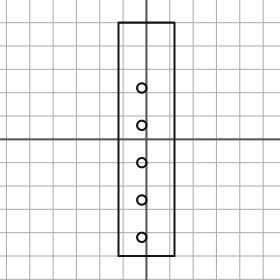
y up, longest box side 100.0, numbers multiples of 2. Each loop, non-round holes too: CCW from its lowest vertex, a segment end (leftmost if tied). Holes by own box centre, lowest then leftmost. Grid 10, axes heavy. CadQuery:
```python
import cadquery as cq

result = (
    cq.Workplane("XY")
    .moveTo(-12.0, -50.0)
    .lineTo(12.0, -50.0)
    .lineTo(12.0, 50.0)
    .lineTo(-12.0, 50.0)
    .close()
    .moveTo(-2.0, -42.0)
    .circle(2.0)
    .moveTo(-2.0, -26.0)
    .circle(2.0)
    .moveTo(-2.0, -10.0)
    .circle(2.0)
    .moveTo(-2.0, 6.0)
    .circle(2.0)
    .moveTo(-2.0, 22.0)
    .circle(2.0)
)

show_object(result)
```